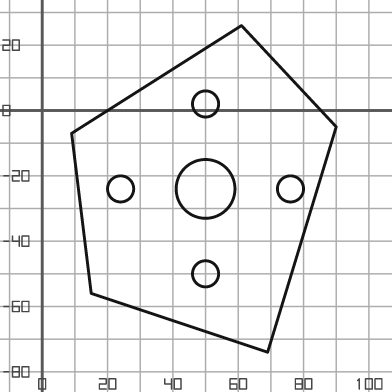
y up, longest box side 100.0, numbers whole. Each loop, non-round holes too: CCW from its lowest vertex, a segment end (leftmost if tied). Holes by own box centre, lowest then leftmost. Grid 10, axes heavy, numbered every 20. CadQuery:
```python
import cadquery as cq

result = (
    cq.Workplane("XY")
    .moveTo(69.0, -74.0)
    .lineTo(90.0, -5.0)
    .lineTo(61.0, 26.0)
    .lineTo(9.0, -7.0)
    .lineTo(15.0, -56.0)
    .close()
    .moveTo(50.0, -50.0)
    .circle(4.0)
    .moveTo(24.0, -24.0)
    .circle(4.0)
    .moveTo(50.0, -24.0)
    .circle(9.0)
    .moveTo(76.0, -24.0)
    .circle(4.0)
    .moveTo(50.0, 2.0)
    .circle(4.0)
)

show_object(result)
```